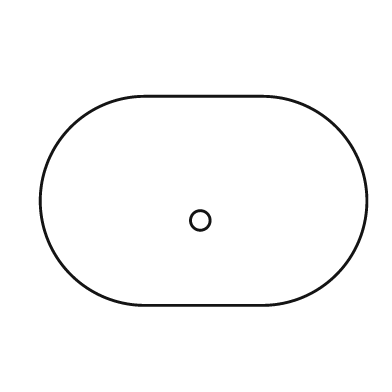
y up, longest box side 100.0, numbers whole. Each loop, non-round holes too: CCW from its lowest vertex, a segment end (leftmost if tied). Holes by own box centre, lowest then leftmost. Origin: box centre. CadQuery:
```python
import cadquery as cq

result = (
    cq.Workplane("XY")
    .moveTo(-18.0, -32.0)
    .lineTo(18.0, -32.0)
    .threePointArc((50.0, 0.0), (18.0, 32.0))
    .lineTo(-18.0, 32.0)
    .threePointArc((-50.0, 0.0), (-18.0, -32.0))
    .close()
    .moveTo(-1.0, -6.0)
    .circle(3.0)
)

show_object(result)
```